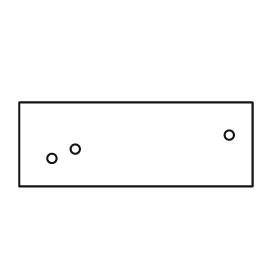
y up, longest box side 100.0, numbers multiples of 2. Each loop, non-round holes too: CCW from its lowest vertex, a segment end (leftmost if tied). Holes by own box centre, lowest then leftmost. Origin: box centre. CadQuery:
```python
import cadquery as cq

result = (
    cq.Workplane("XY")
    .moveTo(-50.0, -18.0)
    .lineTo(50.0, -18.0)
    .lineTo(50.0, 18.0)
    .lineTo(-50.0, 18.0)
    .close()
    .moveTo(-36.0, -6.0)
    .circle(2.0)
    .moveTo(-26.0, -2.0)
    .circle(2.0)
    .moveTo(40.0, 4.0)
    .circle(2.0)
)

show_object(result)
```